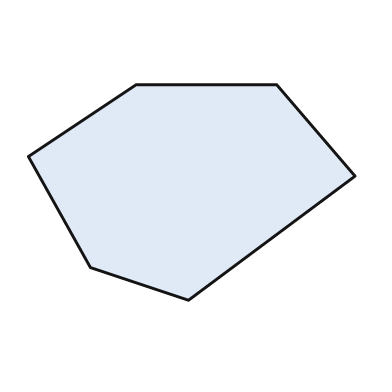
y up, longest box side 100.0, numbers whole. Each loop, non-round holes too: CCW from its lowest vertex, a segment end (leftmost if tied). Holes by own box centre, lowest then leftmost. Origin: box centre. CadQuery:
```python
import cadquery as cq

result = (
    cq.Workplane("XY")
    .moveTo(-1.0, -33.0)
    .lineTo(50.0, 5.0)
    .lineTo(26.0, 33.0)
    .lineTo(-17.0, 33.0)
    .lineTo(-50.0, 11.0)
    .lineTo(-31.0, -23.0)
    .close()
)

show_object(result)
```